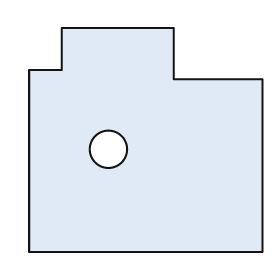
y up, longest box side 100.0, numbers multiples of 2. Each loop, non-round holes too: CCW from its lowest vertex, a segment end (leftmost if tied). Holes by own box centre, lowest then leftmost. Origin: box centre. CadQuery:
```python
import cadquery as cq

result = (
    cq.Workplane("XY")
    .moveTo(-50.0, -48.0)
    .lineTo(50.0, -48.0)
    .lineTo(50.0, 26.0)
    .lineTo(12.0, 26.0)
    .lineTo(12.0, 48.0)
    .lineTo(-36.0, 48.0)
    .lineTo(-36.0, 30.0)
    .lineTo(-50.0, 30.0)
    .close()
    .moveTo(-16.0, -4.0)
    .circle(8.0)
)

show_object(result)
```